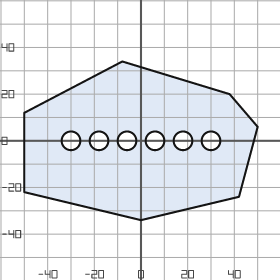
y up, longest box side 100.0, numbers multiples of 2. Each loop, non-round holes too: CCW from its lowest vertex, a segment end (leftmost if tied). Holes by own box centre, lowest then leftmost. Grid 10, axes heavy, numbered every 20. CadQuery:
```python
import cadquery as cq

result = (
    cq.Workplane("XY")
    .moveTo(0.0, -34.0)
    .lineTo(42.0, -24.0)
    .lineTo(50.0, 6.0)
    .lineTo(38.0, 20.0)
    .lineTo(-8.0, 34.0)
    .lineTo(-50.0, 12.0)
    .lineTo(-50.0, -22.0)
    .close()
    .moveTo(-30.0, 0.0)
    .circle(4.0)
    .moveTo(-18.0, 0.0)
    .circle(4.0)
    .moveTo(-6.0, 0.0)
    .circle(4.0)
    .moveTo(6.0, 0.0)
    .circle(4.0)
    .moveTo(18.0, 0.0)
    .circle(4.0)
    .moveTo(30.0, 0.0)
    .circle(4.0)
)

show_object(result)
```